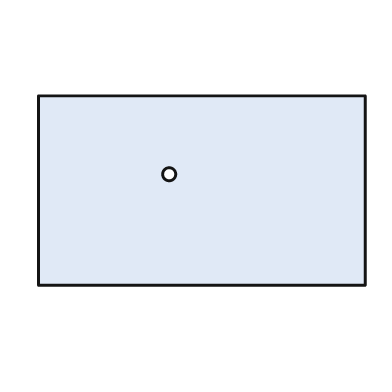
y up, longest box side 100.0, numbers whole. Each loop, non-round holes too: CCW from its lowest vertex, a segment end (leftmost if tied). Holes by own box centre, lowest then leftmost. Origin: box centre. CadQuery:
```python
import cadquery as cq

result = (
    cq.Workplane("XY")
    .moveTo(-50.0, -29.0)
    .lineTo(50.0, -29.0)
    .lineTo(50.0, 29.0)
    .lineTo(-50.0, 29.0)
    .close()
    .moveTo(-10.0, 5.0)
    .circle(2.0)
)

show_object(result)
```